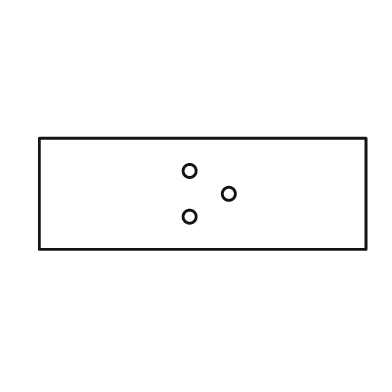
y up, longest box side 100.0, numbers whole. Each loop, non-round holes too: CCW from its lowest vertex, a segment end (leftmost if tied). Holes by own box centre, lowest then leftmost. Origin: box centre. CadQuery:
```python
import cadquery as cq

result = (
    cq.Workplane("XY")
    .moveTo(-50.0, -17.0)
    .lineTo(50.0, -17.0)
    .lineTo(50.0, 17.0)
    .lineTo(-50.0, 17.0)
    .close()
    .moveTo(-4.0, -7.0)
    .circle(2.0)
    .moveTo(8.0, 0.0)
    .circle(2.0)
    .moveTo(-4.0, 7.0)
    .circle(2.0)
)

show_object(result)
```